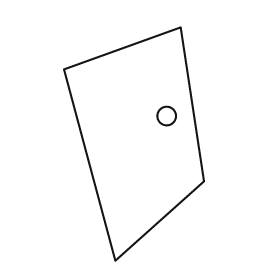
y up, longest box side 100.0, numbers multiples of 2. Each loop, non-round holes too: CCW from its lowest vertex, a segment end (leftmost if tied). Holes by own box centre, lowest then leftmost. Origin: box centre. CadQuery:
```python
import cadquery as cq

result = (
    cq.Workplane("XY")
    .moveTo(-8.0, -50.0)
    .lineTo(30.0, -16.0)
    .lineTo(20.0, 50.0)
    .lineTo(-30.0, 32.0)
    .close()
    .moveTo(14.0, 12.0)
    .circle(4.0)
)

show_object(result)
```